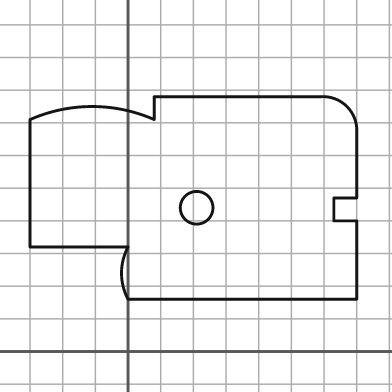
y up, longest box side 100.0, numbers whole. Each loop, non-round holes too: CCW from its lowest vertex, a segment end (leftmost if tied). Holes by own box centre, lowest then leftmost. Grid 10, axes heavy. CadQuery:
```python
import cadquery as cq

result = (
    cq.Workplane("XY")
    .moveTo(0.0, 16.0)
    .lineTo(70.0, 16.0)
    .lineTo(70.0, 40.0)
    .lineTo(63.0, 40.0)
    .lineTo(63.0, 47.0)
    .lineTo(70.0, 47.0)
    .lineTo(70.0, 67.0)
    .threePointArc((67.0, 75.0), (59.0, 78.0))
    .lineTo(8.0, 78.0)
    .lineTo(8.0, 71.0)
    .threePointArc((-11.0, 75.0), (-30.0, 71.0))
    .lineTo(-30.0, 32.0)
    .lineTo(0.0, 32.0)
    .threePointArc((-2.0, 24.0), (0.0, 16.0))
    .close()
    .moveTo(21.0, 44.0)
    .circle(5.0)
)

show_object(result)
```